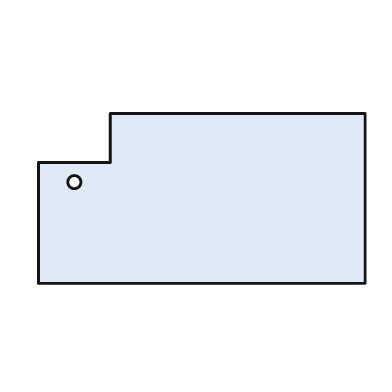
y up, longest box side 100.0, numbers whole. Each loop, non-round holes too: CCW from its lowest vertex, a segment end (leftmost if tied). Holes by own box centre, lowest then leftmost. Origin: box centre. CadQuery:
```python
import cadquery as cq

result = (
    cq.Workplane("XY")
    .moveTo(-50.0, -26.0)
    .lineTo(50.0, -26.0)
    .lineTo(50.0, 26.0)
    .lineTo(-28.0, 26.0)
    .lineTo(-28.0, 11.0)
    .lineTo(-50.0, 11.0)
    .close()
    .moveTo(-39.0, 5.0)
    .circle(2.0)
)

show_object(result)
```